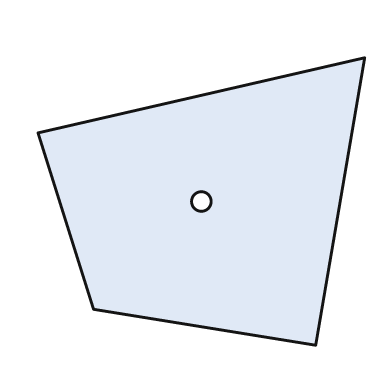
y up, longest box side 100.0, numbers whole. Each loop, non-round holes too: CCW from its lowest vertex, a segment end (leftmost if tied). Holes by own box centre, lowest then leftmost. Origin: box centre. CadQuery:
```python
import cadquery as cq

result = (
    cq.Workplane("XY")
    .moveTo(35.0, -44.0)
    .lineTo(50.0, 44.0)
    .lineTo(-50.0, 21.0)
    .lineTo(-33.0, -33.0)
    .close()
    .moveTo(0.0, 0.0)
    .circle(3.0)
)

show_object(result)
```